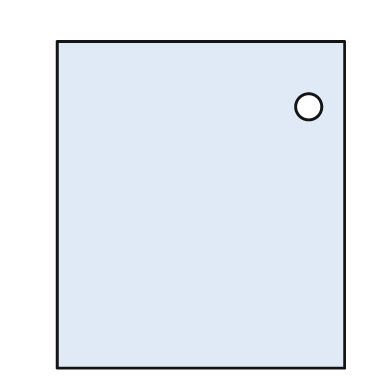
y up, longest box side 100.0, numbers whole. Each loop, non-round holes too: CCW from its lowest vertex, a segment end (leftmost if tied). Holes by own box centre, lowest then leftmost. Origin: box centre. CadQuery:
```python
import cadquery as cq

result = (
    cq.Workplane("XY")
    .moveTo(-44.0, -50.0)
    .lineTo(44.0, -50.0)
    .lineTo(44.0, 50.0)
    .lineTo(-44.0, 50.0)
    .close()
    .moveTo(33.0, 30.0)
    .circle(4.0)
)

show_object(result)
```